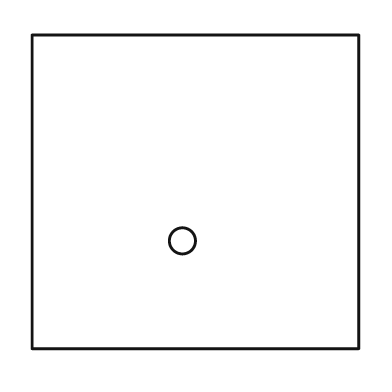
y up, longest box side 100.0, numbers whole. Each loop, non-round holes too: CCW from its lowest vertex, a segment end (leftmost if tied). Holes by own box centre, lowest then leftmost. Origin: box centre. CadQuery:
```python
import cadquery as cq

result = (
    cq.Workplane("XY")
    .moveTo(-50.0, -48.0)
    .lineTo(50.0, -48.0)
    .lineTo(50.0, 48.0)
    .lineTo(-50.0, 48.0)
    .close()
    .moveTo(-4.0, -15.0)
    .circle(4.0)
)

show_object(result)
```